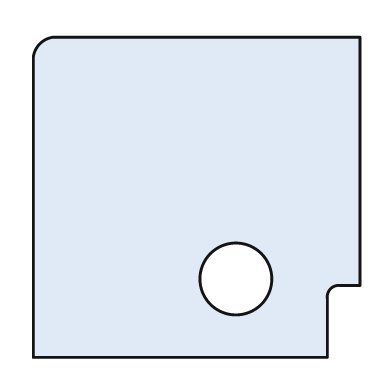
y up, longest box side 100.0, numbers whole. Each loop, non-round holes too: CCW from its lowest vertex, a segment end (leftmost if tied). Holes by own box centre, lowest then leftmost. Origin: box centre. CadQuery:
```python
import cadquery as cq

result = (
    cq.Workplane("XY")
    .moveTo(-50.0, -49.0)
    .lineTo(40.0, -49.0)
    .lineTo(40.0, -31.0)
    .threePointArc((41.0, -28.0), (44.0, -27.0))
    .lineTo(50.0, -27.0)
    .lineTo(50.0, 49.0)
    .lineTo(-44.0, 49.0)
    .threePointArc((-48.0, 47.0), (-50.0, 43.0))
    .close()
    .moveTo(12.0, -25.0)
    .circle(11.0)
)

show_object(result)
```